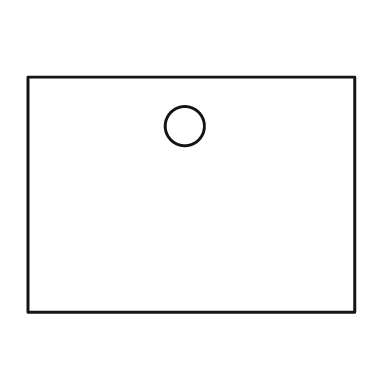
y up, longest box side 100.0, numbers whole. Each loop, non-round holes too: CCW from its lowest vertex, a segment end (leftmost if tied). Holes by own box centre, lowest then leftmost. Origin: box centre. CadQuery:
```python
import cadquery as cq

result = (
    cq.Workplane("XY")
    .moveTo(-50.0, -36.0)
    .lineTo(50.0, -36.0)
    .lineTo(50.0, 36.0)
    .lineTo(-50.0, 36.0)
    .close()
    .moveTo(-2.0, 21.0)
    .circle(6.0)
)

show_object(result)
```